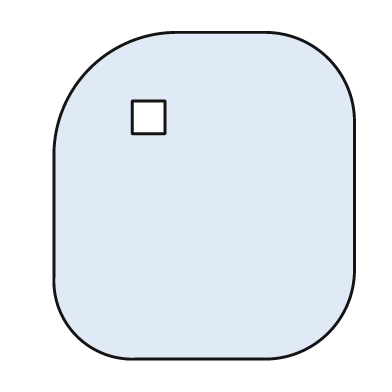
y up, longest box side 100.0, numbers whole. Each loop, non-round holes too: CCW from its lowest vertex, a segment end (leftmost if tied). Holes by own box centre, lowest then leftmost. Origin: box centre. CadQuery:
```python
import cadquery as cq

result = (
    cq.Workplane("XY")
    .moveTo(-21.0, -50.0)
    .lineTo(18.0, -50.0)
    .threePointArc((38.0, -42.0), (46.0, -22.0))
    .lineTo(46.0, 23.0)
    .threePointArc((38.0, 42.0), (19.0, 50.0))
    .lineTo(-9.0, 50.0)
    .threePointArc((-35.0, 39.0), (-46.0, 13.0))
    .lineTo(-46.0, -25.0)
    .threePointArc((-39.0, -43.0), (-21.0, -50.0))
    .close()
    .moveTo(-22.0, 19.0)
    .lineTo(-12.0, 19.0)
    .lineTo(-12.0, 29.0)
    .lineTo(-22.0, 29.0)
    .close()
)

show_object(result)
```